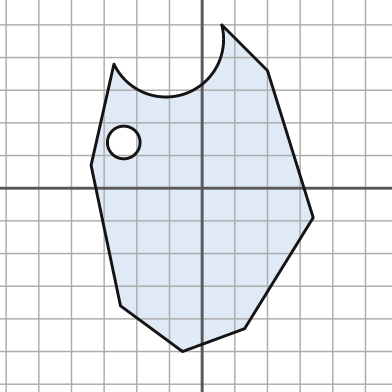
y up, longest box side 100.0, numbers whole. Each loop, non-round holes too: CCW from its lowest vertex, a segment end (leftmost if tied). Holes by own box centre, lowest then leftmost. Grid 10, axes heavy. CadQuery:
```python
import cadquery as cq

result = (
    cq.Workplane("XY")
    .moveTo(-6.0, -50.0)
    .lineTo(13.0, -43.0)
    .lineTo(34.0, -9.0)
    .lineTo(20.0, 36.0)
    .lineTo(6.0, 50.0)
    .threePointArc((-5.0, 29.0), (-27.0, 38.0))
    .lineTo(-34.0, 7.0)
    .lineTo(-25.0, -36.0)
    .close()
    .moveTo(-24.0, 14.0)
    .circle(5.0)
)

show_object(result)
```